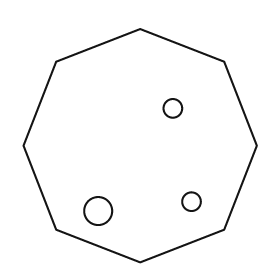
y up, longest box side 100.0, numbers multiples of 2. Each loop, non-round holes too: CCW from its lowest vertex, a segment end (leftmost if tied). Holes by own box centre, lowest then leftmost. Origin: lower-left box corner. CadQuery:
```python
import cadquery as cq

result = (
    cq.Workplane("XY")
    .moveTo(50.0, 0.0)
    .lineTo(86.0, 14.0)
    .lineTo(100.0, 50.0)
    .lineTo(86.0, 86.0)
    .lineTo(50.0, 100.0)
    .lineTo(14.0, 86.0)
    .lineTo(0.0, 50.0)
    .lineTo(14.0, 14.0)
    .close()
    .moveTo(32.0, 22.0)
    .circle(6.0)
    .moveTo(72.0, 26.0)
    .circle(4.0)
    .moveTo(64.0, 66.0)
    .circle(4.0)
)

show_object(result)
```